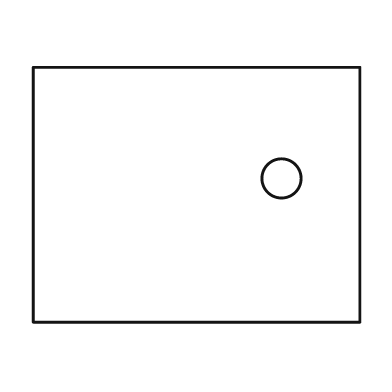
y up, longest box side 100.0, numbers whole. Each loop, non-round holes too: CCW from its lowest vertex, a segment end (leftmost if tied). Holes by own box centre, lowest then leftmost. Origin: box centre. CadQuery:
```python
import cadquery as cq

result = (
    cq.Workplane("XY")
    .moveTo(-50.0, -39.0)
    .lineTo(50.0, -39.0)
    .lineTo(50.0, 39.0)
    .lineTo(-50.0, 39.0)
    .close()
    .moveTo(26.0, 5.0)
    .circle(6.0)
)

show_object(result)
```